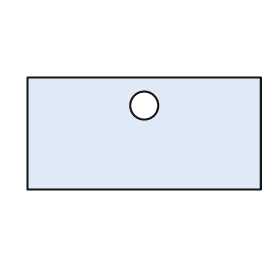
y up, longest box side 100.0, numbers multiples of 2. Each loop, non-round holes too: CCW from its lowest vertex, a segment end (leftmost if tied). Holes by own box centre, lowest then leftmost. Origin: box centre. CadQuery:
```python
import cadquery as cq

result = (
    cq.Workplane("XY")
    .moveTo(-50.0, -24.0)
    .lineTo(50.0, -24.0)
    .lineTo(50.0, 24.0)
    .lineTo(-50.0, 24.0)
    .close()
    .moveTo(0.0, 12.0)
    .circle(6.0)
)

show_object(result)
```